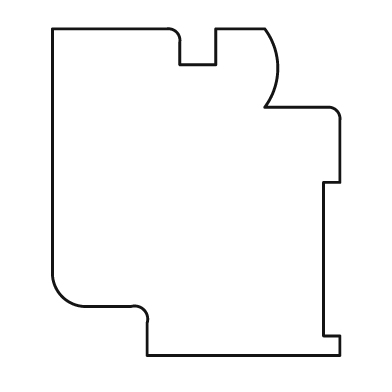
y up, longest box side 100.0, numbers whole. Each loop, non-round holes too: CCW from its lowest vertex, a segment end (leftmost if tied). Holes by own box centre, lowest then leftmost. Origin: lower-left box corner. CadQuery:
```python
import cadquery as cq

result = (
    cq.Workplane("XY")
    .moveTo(29.0, 0.0)
    .lineTo(88.0, 0.0)
    .lineTo(88.0, 6.0)
    .lineTo(83.0, 6.0)
    .lineTo(83.0, 53.0)
    .lineTo(88.0, 53.0)
    .lineTo(88.0, 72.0)
    .threePointArc((87.0, 75.0), (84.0, 76.0))
    .lineTo(65.0, 76.0)
    .threePointArc((69.0, 88.0), (65.0, 100.0))
    .lineTo(50.0, 100.0)
    .lineTo(50.0, 89.0)
    .lineTo(39.0, 89.0)
    .lineTo(39.0, 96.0)
    .threePointArc((38.0, 99.0), (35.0, 100.0))
    .lineTo(0.0, 100.0)
    .lineTo(0.0, 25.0)
    .threePointArc((3.0, 18.0), (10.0, 15.0))
    .lineTo(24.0, 15.0)
    .threePointArc((28.0, 14.0), (29.0, 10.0))
    .close()
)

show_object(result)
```